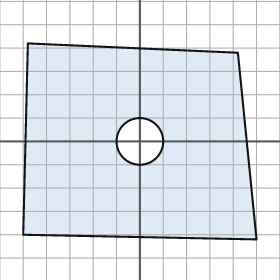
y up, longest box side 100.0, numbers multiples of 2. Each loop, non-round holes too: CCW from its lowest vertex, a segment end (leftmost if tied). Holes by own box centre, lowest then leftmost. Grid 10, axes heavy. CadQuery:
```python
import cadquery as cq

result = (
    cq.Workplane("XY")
    .moveTo(50.0, -42.0)
    .lineTo(42.0, 38.0)
    .lineTo(-48.0, 42.0)
    .lineTo(-50.0, -40.0)
    .close()
    .moveTo(0.0, 0.0)
    .circle(10.0)
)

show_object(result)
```